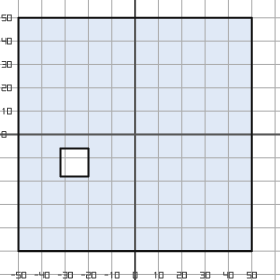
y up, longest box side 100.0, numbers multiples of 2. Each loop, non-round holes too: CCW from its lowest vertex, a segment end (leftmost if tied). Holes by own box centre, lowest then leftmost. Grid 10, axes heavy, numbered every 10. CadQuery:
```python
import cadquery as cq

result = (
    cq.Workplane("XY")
    .moveTo(-50.0, -50.0)
    .lineTo(50.0, -50.0)
    .lineTo(50.0, 50.0)
    .lineTo(-50.0, 50.0)
    .close()
    .moveTo(-32.0, -18.0)
    .lineTo(-20.0, -18.0)
    .lineTo(-20.0, -6.0)
    .lineTo(-32.0, -6.0)
    .close()
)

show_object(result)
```